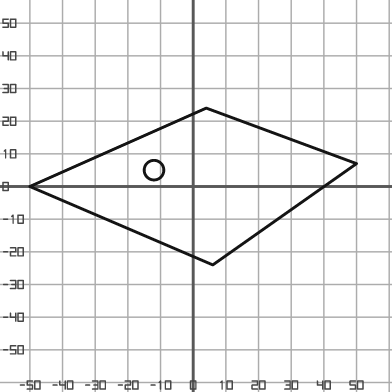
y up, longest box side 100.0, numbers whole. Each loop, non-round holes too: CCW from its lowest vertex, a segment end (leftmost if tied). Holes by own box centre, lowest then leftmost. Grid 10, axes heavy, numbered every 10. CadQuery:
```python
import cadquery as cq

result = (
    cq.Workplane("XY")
    .moveTo(6.0, -24.0)
    .lineTo(50.0, 7.0)
    .lineTo(4.0, 24.0)
    .lineTo(-50.0, 0.0)
    .close()
    .moveTo(-12.0, 5.0)
    .circle(3.0)
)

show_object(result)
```